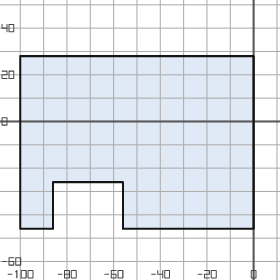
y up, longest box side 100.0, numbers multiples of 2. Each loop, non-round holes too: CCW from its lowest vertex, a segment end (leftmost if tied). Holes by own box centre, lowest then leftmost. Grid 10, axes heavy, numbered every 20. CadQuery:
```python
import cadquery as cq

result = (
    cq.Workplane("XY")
    .moveTo(-100.0, -46.0)
    .lineTo(-86.0, -46.0)
    .lineTo(-86.0, -26.0)
    .lineTo(-56.0, -26.0)
    .lineTo(-56.0, -46.0)
    .lineTo(0.0, -46.0)
    .lineTo(0.0, 28.0)
    .lineTo(-100.0, 28.0)
    .close()
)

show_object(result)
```